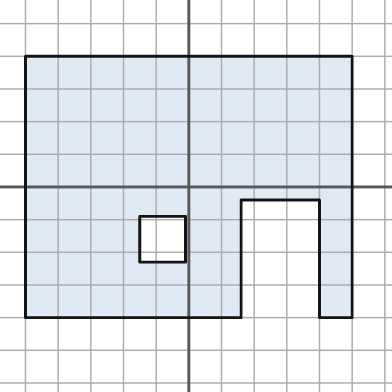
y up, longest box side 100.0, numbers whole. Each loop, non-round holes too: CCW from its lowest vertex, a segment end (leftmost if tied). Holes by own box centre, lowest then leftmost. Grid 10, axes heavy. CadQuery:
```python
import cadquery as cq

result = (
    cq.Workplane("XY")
    .moveTo(-50.0, -40.0)
    .lineTo(16.0, -40.0)
    .lineTo(16.0, -4.0)
    .lineTo(40.0, -4.0)
    .lineTo(40.0, -40.0)
    .lineTo(50.0, -40.0)
    .lineTo(50.0, 40.0)
    .lineTo(-50.0, 40.0)
    .close()
    .moveTo(-15.0, -23.0)
    .lineTo(-1.0, -23.0)
    .lineTo(-1.0, -9.0)
    .lineTo(-15.0, -9.0)
    .close()
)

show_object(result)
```